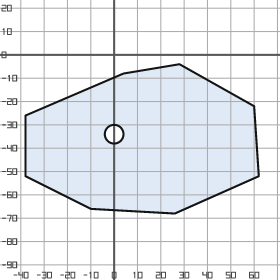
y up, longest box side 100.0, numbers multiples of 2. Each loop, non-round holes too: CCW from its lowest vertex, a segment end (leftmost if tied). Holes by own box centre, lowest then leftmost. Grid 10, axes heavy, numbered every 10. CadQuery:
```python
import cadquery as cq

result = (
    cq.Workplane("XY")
    .moveTo(26.0, -68.0)
    .lineTo(62.0, -52.0)
    .lineTo(60.0, -22.0)
    .lineTo(28.0, -4.0)
    .lineTo(4.0, -8.0)
    .lineTo(-38.0, -26.0)
    .lineTo(-38.0, -52.0)
    .lineTo(-10.0, -66.0)
    .close()
    .moveTo(0.0, -34.0)
    .circle(4.0)
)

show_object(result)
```